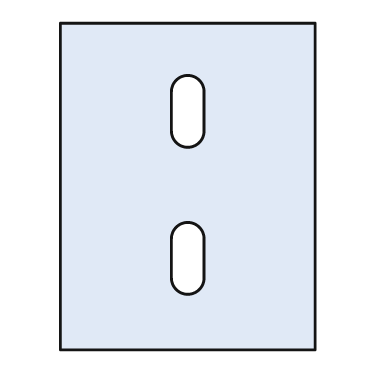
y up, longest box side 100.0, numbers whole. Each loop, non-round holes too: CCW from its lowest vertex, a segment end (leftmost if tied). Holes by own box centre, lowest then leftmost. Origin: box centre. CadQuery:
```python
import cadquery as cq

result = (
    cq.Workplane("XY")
    .moveTo(-39.0, -50.0)
    .lineTo(39.0, -50.0)
    .lineTo(39.0, 50.0)
    .lineTo(-39.0, 50.0)
    .close()
    .moveTo(-5.0, -28.0)
    .threePointArc((0.0, -33.0), (5.0, -28.0))
    .lineTo(5.0, -16.0)
    .threePointArc((0.0, -11.0), (-5.0, -16.0))
    .close()
    .moveTo(-5.0, 17.0)
    .threePointArc((0.0, 12.0), (5.0, 17.0))
    .lineTo(5.0, 29.0)
    .threePointArc((0.0, 34.0), (-5.0, 29.0))
    .close()
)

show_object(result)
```